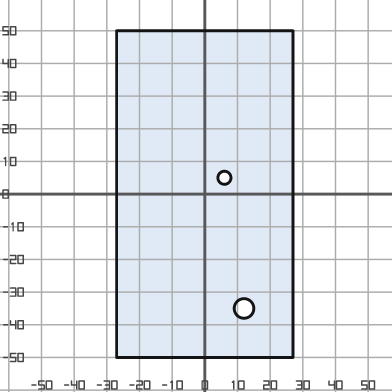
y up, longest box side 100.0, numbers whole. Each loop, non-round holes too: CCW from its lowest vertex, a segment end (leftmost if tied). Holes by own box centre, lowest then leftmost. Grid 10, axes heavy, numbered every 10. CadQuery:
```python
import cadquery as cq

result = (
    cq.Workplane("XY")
    .moveTo(-27.0, -50.0)
    .lineTo(27.0, -50.0)
    .lineTo(27.0, 50.0)
    .lineTo(-27.0, 50.0)
    .close()
    .moveTo(12.0, -35.0)
    .circle(3.0)
    .moveTo(6.0, 5.0)
    .circle(2.0)
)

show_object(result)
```